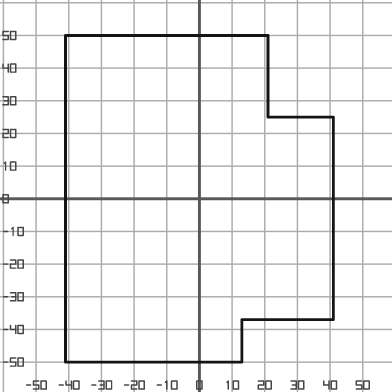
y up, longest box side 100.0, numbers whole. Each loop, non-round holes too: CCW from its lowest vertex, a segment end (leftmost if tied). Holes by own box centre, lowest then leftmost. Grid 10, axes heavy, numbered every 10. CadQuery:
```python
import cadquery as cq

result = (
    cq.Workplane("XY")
    .moveTo(-41.0, -50.0)
    .lineTo(13.0, -50.0)
    .lineTo(13.0, -37.0)
    .lineTo(41.0, -37.0)
    .lineTo(41.0, 25.0)
    .lineTo(21.0, 25.0)
    .lineTo(21.0, 50.0)
    .lineTo(-41.0, 50.0)
    .close()
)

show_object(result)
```